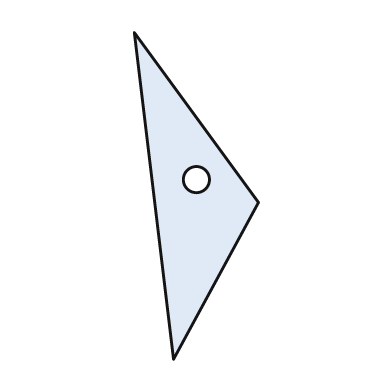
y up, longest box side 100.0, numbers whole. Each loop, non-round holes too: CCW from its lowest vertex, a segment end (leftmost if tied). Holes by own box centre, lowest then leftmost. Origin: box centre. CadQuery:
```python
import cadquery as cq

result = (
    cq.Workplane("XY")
    .moveTo(-7.0, -50.0)
    .lineTo(19.0, -2.0)
    .lineTo(-19.0, 50.0)
    .close()
    .moveTo(0.0, 5.0)
    .circle(4.0)
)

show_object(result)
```